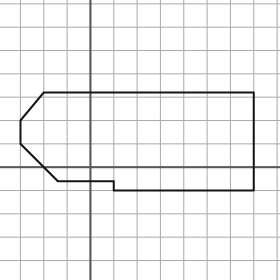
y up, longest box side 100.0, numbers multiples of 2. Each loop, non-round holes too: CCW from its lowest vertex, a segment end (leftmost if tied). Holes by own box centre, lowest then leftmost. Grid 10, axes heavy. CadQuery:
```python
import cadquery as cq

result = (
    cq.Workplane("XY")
    .moveTo(10.0, -10.0)
    .lineTo(70.0, -10.0)
    .lineTo(70.0, 32.0)
    .lineTo(-20.0, 32.0)
    .lineTo(-30.0, 20.0)
    .lineTo(-30.0, 10.0)
    .lineTo(-14.0, -6.0)
    .lineTo(10.0, -6.0)
    .close()
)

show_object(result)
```